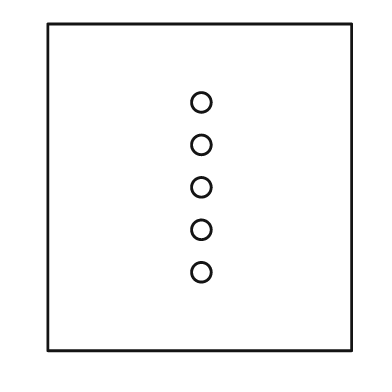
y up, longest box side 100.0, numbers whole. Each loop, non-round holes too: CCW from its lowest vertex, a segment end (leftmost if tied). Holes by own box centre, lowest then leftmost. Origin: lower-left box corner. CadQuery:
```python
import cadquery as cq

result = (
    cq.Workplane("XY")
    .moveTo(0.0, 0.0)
    .lineTo(93.0, 0.0)
    .lineTo(93.0, 100.0)
    .lineTo(0.0, 100.0)
    .close()
    .moveTo(47.0, 24.0)
    .circle(3.0)
    .moveTo(47.0, 37.0)
    .circle(3.0)
    .moveTo(47.0, 50.0)
    .circle(3.0)
    .moveTo(47.0, 63.0)
    .circle(3.0)
    .moveTo(47.0, 76.0)
    .circle(3.0)
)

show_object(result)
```